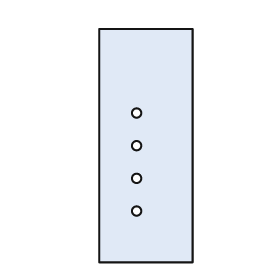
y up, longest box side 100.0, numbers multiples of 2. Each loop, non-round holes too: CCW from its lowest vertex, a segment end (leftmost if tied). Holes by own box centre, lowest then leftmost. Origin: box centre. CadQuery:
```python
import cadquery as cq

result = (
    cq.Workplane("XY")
    .moveTo(-20.0, -50.0)
    .lineTo(20.0, -50.0)
    .lineTo(20.0, 50.0)
    .lineTo(-20.0, 50.0)
    .close()
    .moveTo(-4.0, -28.0)
    .circle(2.0)
    .moveTo(-4.0, -14.0)
    .circle(2.0)
    .moveTo(-4.0, 0.0)
    .circle(2.0)
    .moveTo(-4.0, 14.0)
    .circle(2.0)
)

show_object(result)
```